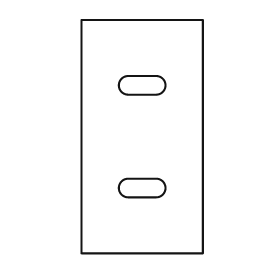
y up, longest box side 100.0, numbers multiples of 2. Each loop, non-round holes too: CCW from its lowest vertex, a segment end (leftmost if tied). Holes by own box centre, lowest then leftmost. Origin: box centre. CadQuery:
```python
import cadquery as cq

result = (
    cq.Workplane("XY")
    .moveTo(-26.0, -50.0)
    .lineTo(26.0, -50.0)
    .lineTo(26.0, 50.0)
    .lineTo(-26.0, 50.0)
    .close()
    .moveTo(-6.0, -26.0)
    .lineTo(6.0, -26.0)
    .threePointArc((10.0, -22.0), (6.0, -18.0))
    .lineTo(-6.0, -18.0)
    .threePointArc((-10.0, -22.0), (-6.0, -26.0))
    .close()
    .moveTo(-6.0, 18.0)
    .lineTo(6.0, 18.0)
    .threePointArc((10.0, 22.0), (6.0, 26.0))
    .lineTo(-6.0, 26.0)
    .threePointArc((-10.0, 22.0), (-6.0, 18.0))
    .close()
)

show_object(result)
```